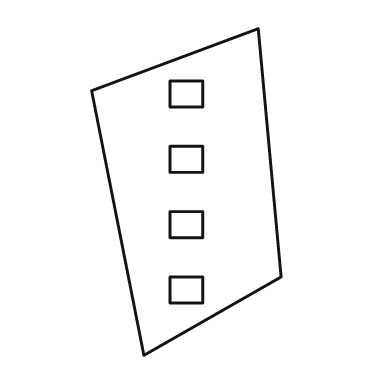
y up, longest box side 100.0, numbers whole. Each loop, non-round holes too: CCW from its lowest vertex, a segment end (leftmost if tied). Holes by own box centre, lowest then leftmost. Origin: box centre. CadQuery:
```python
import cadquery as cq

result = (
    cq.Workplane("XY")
    .moveTo(-13.0, -50.0)
    .lineTo(29.0, -26.0)
    .lineTo(22.0, 50.0)
    .lineTo(-29.0, 31.0)
    .close()
    .moveTo(-5.0, -34.0)
    .lineTo(5.0, -34.0)
    .lineTo(5.0, -26.0)
    .lineTo(-5.0, -26.0)
    .close()
    .moveTo(-5.0, -14.0)
    .lineTo(5.0, -14.0)
    .lineTo(5.0, -6.0)
    .lineTo(-5.0, -6.0)
    .close()
    .moveTo(-5.0, 6.0)
    .lineTo(5.0, 6.0)
    .lineTo(5.0, 14.0)
    .lineTo(-5.0, 14.0)
    .close()
    .moveTo(-5.0, 26.0)
    .lineTo(5.0, 26.0)
    .lineTo(5.0, 34.0)
    .lineTo(-5.0, 34.0)
    .close()
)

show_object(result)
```